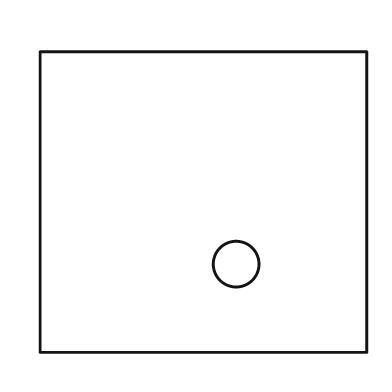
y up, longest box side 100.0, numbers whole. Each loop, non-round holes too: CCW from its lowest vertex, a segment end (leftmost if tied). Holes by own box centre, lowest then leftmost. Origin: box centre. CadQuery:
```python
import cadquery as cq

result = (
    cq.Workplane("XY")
    .moveTo(-50.0, -46.0)
    .lineTo(50.0, -46.0)
    .lineTo(50.0, 46.0)
    .lineTo(-50.0, 46.0)
    .close()
    .moveTo(10.0, -19.0)
    .circle(7.0)
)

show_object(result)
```